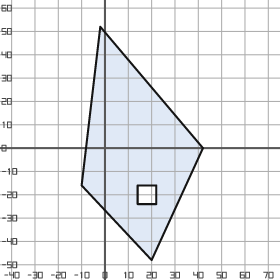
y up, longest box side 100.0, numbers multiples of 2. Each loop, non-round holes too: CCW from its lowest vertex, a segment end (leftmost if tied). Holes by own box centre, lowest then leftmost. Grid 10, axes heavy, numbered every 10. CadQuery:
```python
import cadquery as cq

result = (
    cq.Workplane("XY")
    .moveTo(20.0, -48.0)
    .lineTo(42.0, 0.0)
    .lineTo(-2.0, 52.0)
    .lineTo(-10.0, -16.0)
    .close()
    .moveTo(14.0, -24.0)
    .lineTo(22.0, -24.0)
    .lineTo(22.0, -16.0)
    .lineTo(14.0, -16.0)
    .close()
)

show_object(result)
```